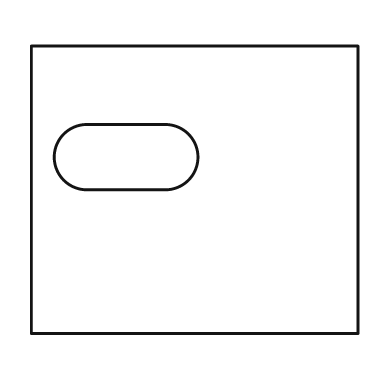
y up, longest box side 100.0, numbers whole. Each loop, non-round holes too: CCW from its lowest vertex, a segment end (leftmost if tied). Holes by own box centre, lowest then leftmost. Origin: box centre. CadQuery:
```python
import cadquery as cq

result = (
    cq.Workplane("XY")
    .moveTo(-50.0, -44.0)
    .lineTo(50.0, -44.0)
    .lineTo(50.0, 44.0)
    .lineTo(-50.0, 44.0)
    .close()
    .moveTo(-33.0, 0.0)
    .lineTo(-9.0, 0.0)
    .threePointArc((1.0, 10.0), (-9.0, 20.0))
    .lineTo(-33.0, 20.0)
    .threePointArc((-43.0, 10.0), (-33.0, 0.0))
    .close()
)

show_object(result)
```